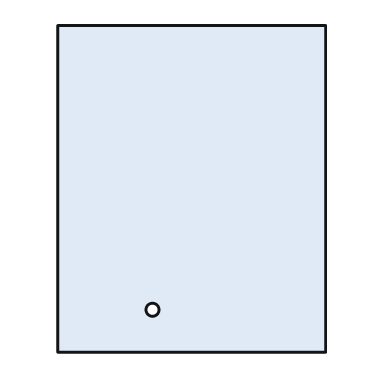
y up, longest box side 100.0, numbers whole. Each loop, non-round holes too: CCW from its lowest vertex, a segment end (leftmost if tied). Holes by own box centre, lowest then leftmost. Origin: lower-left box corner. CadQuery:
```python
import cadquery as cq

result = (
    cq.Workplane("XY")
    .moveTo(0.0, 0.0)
    .lineTo(82.0, 0.0)
    .lineTo(82.0, 100.0)
    .lineTo(0.0, 100.0)
    .close()
    .moveTo(29.0, 13.0)
    .circle(2.0)
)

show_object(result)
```